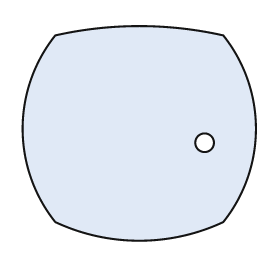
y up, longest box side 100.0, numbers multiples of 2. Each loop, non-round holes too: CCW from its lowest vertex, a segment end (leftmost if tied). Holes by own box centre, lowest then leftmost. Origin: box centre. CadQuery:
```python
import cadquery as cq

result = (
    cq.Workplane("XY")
    .moveTo(-36.0, -38.0)
    .threePointArc((0.0, -46.0), (36.0, -38.0))
    .threePointArc((50.0, 2.0), (36.0, 42.0))
    .threePointArc((0.0, 46.0), (-36.0, 42.0))
    .threePointArc((-50.0, 2.0), (-36.0, -38.0))
    .close()
    .moveTo(28.0, -4.0)
    .circle(4.0)
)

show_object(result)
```